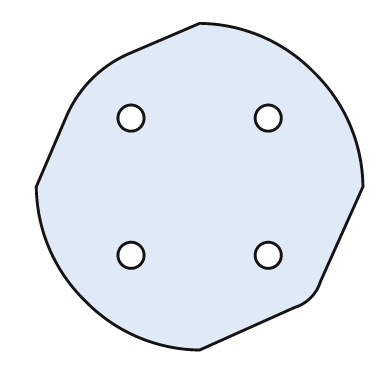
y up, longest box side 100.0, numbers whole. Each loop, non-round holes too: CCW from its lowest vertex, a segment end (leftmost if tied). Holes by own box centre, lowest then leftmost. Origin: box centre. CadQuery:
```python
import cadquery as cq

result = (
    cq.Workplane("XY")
    .moveTo(0.0, -50.0)
    .lineTo(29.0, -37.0)
    .threePointArc((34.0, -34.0), (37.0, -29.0))
    .lineTo(50.0, 0.0)
    .threePointArc((46.0, 19.0), (35.0, 35.0))
    .threePointArc((19.0, 46.0), (0.0, 50.0))
    .lineTo(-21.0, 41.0)
    .threePointArc((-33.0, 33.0), (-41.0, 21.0))
    .lineTo(-50.0, 0.0)
    .threePointArc((-46.0, -19.0), (-35.0, -35.0))
    .threePointArc((-19.0, -46.0), (0.0, -50.0))
    .close()
    .moveTo(-21.0, -21.0)
    .circle(4.0)
    .moveTo(21.0, -21.0)
    .circle(4.0)
    .moveTo(-21.0, 21.0)
    .circle(4.0)
    .moveTo(21.0, 21.0)
    .circle(4.0)
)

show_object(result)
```